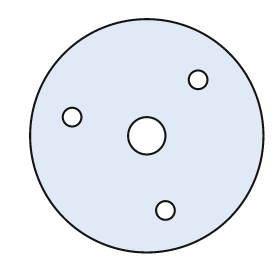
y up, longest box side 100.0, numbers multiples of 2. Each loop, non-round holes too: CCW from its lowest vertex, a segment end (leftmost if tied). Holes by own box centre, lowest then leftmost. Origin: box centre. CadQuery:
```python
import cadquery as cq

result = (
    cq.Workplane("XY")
    .moveTo(0.0, 0.0)
    .circle(50.0)
    .moveTo(8.0, -32.0)
    .circle(4.0)
    .moveTo(0.0, 0.0)
    .circle(8.0)
    .moveTo(-32.0, 8.0)
    .circle(4.0)
    .moveTo(22.0, 24.0)
    .circle(4.0)
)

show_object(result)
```